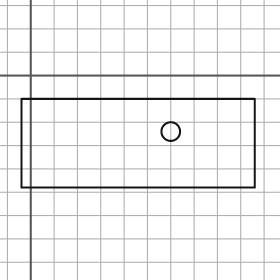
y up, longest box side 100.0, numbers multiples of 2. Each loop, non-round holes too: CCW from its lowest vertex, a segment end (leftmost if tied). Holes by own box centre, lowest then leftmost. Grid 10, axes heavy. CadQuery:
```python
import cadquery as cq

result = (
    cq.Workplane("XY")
    .moveTo(-4.0, -48.0)
    .lineTo(96.0, -48.0)
    .lineTo(96.0, -10.0)
    .lineTo(-4.0, -10.0)
    .close()
    .moveTo(60.0, -24.0)
    .circle(4.0)
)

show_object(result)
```